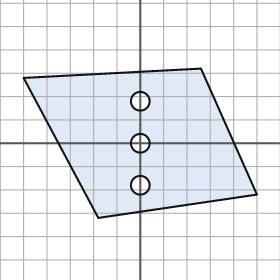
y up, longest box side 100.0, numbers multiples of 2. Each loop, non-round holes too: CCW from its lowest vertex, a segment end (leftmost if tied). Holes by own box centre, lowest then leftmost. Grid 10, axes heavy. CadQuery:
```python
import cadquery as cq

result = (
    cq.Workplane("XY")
    .moveTo(-18.0, -32.0)
    .lineTo(50.0, -22.0)
    .lineTo(26.0, 32.0)
    .lineTo(-50.0, 28.0)
    .close()
    .moveTo(0.0, -18.0)
    .circle(4.0)
    .moveTo(0.0, 0.0)
    .circle(4.0)
    .moveTo(0.0, 18.0)
    .circle(4.0)
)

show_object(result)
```